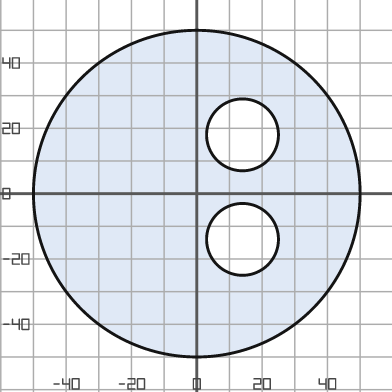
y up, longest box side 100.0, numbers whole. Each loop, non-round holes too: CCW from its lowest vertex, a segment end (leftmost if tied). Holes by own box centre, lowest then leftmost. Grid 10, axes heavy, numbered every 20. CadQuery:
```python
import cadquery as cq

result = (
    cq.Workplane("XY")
    .moveTo(0.0, 0.0)
    .circle(50.0)
    .moveTo(14.0, -14.0)
    .circle(11.0)
    .moveTo(14.0, 18.0)
    .circle(11.0)
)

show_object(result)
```